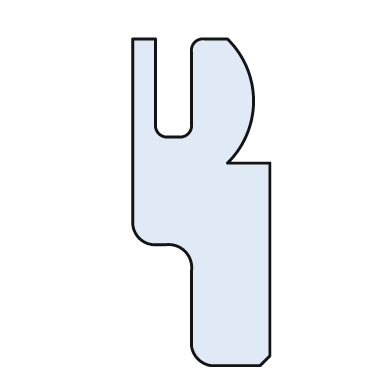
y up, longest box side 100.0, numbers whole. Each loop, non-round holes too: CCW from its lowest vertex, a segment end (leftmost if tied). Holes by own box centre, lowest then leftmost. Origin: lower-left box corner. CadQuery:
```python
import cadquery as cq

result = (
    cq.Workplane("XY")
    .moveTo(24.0, 0.0)
    .lineTo(39.0, 0.0)
    .lineTo(42.0, 3.0)
    .lineTo(42.0, 62.0)
    .lineTo(29.0, 62.0)
    .threePointArc((37.0, 81.0), (29.0, 100.0))
    .lineTo(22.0, 100.0)
    .threePointArc((19.0, 99.0), (18.0, 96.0))
    .lineTo(18.0, 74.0)
    .threePointArc((17.0, 71.0), (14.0, 70.0))
    .lineTo(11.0, 70.0)
    .threePointArc((8.0, 71.0), (7.0, 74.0))
    .lineTo(7.0, 100.0)
    .lineTo(0.0, 100.0)
    .lineTo(0.0, 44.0)
    .threePointArc((2.0, 39.0), (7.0, 37.0))
    .lineTo(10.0, 37.0)
    .threePointArc((16.0, 35.0), (18.0, 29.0))
    .lineTo(18.0, 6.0)
    .threePointArc((20.0, 2.0), (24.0, 0.0))
    .close()
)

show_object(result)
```